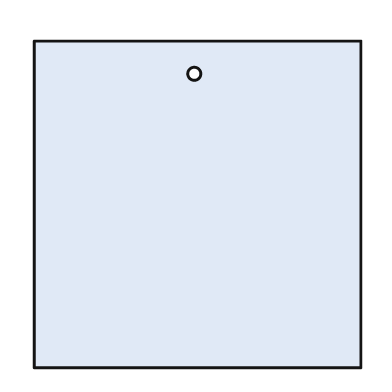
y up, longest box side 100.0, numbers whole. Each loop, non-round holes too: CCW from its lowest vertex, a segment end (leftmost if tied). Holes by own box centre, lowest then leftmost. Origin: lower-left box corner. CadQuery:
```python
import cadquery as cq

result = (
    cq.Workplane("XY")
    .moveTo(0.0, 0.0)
    .lineTo(100.0, 0.0)
    .lineTo(100.0, 100.0)
    .lineTo(0.0, 100.0)
    .close()
    .moveTo(49.0, 90.0)
    .circle(2.0)
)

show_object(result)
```